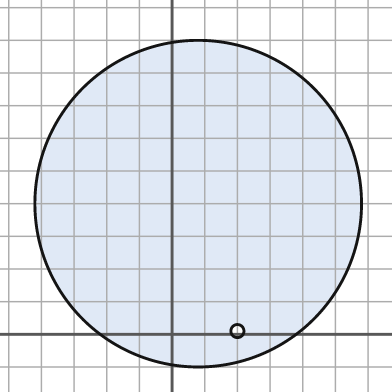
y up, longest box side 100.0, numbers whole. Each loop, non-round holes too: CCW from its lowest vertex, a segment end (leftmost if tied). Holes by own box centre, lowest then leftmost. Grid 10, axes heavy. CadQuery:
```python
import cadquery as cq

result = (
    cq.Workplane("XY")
    .moveTo(8.0, 40.0)
    .circle(50.0)
    .moveTo(20.0, 1.0)
    .circle(2.0)
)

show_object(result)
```